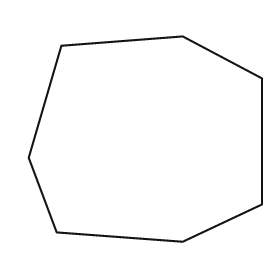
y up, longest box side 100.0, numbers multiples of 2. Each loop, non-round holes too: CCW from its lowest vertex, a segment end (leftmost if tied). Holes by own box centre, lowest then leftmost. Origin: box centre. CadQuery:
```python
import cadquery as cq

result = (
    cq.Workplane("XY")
    .moveTo(16.0, -44.0)
    .lineTo(50.0, -28.0)
    .lineTo(50.0, 26.0)
    .lineTo(16.0, 44.0)
    .lineTo(-36.0, 40.0)
    .lineTo(-50.0, -8.0)
    .lineTo(-38.0, -40.0)
    .close()
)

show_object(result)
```